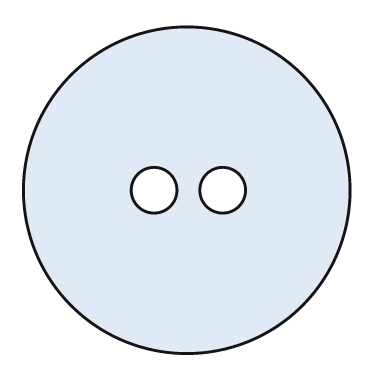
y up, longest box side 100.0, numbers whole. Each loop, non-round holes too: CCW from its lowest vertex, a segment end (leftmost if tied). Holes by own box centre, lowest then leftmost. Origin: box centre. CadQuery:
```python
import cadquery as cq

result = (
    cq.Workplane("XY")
    .moveTo(0.0, 0.0)
    .circle(50.0)
    .moveTo(-10.0, 0.0)
    .circle(7.0)
    .moveTo(11.0, 0.0)
    .circle(7.0)
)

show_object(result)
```